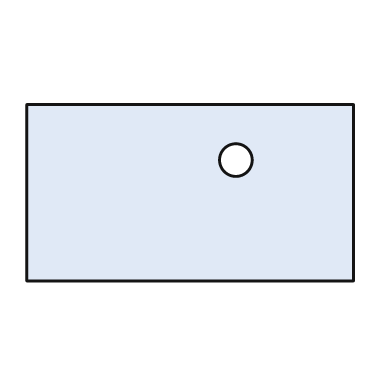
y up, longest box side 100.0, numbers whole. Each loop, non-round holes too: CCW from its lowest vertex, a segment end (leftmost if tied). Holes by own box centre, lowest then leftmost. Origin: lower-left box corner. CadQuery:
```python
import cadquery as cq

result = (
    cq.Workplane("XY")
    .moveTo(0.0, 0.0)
    .lineTo(100.0, 0.0)
    .lineTo(100.0, 54.0)
    .lineTo(0.0, 54.0)
    .close()
    .moveTo(64.0, 37.0)
    .circle(5.0)
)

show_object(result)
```